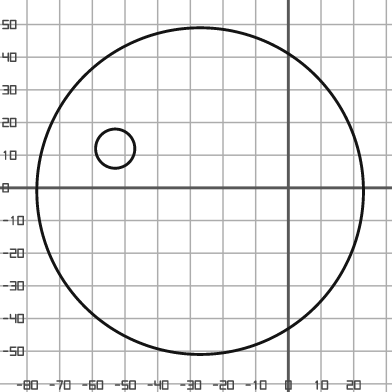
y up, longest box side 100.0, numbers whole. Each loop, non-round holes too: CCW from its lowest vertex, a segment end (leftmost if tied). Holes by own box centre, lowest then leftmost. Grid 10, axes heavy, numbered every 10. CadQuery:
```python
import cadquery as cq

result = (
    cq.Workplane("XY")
    .moveTo(-27.0, -1.0)
    .circle(50.0)
    .moveTo(-53.0, 12.0)
    .circle(6.0)
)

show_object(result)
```